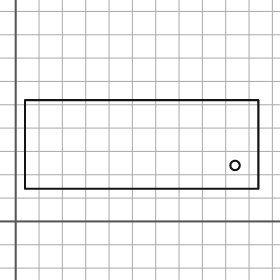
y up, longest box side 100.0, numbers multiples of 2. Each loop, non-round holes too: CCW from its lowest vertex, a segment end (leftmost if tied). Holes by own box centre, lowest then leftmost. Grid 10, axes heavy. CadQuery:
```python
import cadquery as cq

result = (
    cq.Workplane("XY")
    .moveTo(4.0, 14.0)
    .lineTo(104.0, 14.0)
    .lineTo(104.0, 52.0)
    .lineTo(4.0, 52.0)
    .close()
    .moveTo(94.0, 24.0)
    .circle(2.0)
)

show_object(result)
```